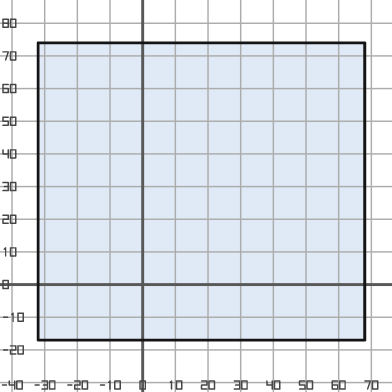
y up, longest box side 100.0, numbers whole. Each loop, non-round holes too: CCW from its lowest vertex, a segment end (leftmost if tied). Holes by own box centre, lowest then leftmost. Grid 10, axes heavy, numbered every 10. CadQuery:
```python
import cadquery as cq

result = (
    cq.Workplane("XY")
    .moveTo(-32.0, -17.0)
    .lineTo(68.0, -17.0)
    .lineTo(68.0, 74.0)
    .lineTo(-32.0, 74.0)
    .close()
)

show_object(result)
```